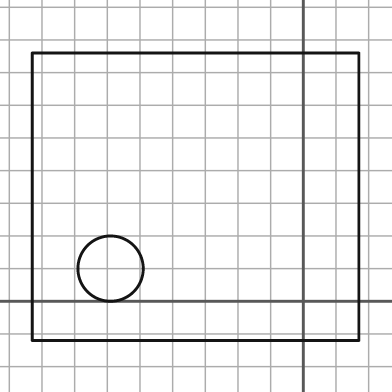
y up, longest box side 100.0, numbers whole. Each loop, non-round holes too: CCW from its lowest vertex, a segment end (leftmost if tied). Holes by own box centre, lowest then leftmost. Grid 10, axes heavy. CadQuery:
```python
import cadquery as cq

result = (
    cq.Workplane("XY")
    .moveTo(-83.0, -12.0)
    .lineTo(17.0, -12.0)
    .lineTo(17.0, 76.0)
    .lineTo(-83.0, 76.0)
    .close()
    .moveTo(-59.0, 10.0)
    .circle(10.0)
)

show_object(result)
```